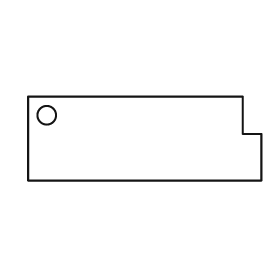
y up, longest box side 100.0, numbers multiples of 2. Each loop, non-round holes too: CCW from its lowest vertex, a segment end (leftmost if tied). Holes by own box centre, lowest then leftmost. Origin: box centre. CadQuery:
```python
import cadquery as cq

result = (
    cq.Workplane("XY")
    .moveTo(-50.0, -18.0)
    .lineTo(50.0, -18.0)
    .lineTo(50.0, 2.0)
    .lineTo(42.0, 2.0)
    .lineTo(42.0, 18.0)
    .lineTo(-50.0, 18.0)
    .close()
    .moveTo(-42.0, 10.0)
    .circle(4.0)
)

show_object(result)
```